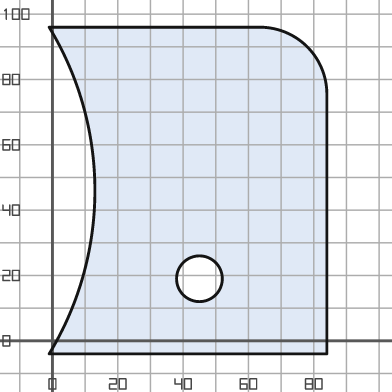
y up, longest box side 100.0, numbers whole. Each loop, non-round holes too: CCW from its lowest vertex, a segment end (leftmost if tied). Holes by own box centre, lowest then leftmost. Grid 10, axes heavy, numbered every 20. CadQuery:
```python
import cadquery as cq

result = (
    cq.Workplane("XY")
    .moveTo(-1.0, -4.0)
    .lineTo(84.0, -4.0)
    .lineTo(84.0, 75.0)
    .threePointArc((78.0, 90.0), (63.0, 96.0))
    .lineTo(-1.0, 96.0)
    .threePointArc((13.0, 46.0), (-1.0, -4.0))
    .close()
    .moveTo(45.0, 19.0)
    .circle(7.0)
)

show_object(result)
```